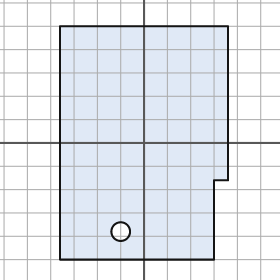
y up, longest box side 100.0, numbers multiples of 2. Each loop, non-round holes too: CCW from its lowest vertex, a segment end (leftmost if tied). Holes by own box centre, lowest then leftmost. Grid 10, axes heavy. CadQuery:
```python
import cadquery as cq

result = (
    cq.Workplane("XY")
    .moveTo(-36.0, -50.0)
    .lineTo(30.0, -50.0)
    .lineTo(30.0, -16.0)
    .lineTo(36.0, -16.0)
    .lineTo(36.0, 50.0)
    .lineTo(-36.0, 50.0)
    .close()
    .moveTo(-10.0, -38.0)
    .circle(4.0)
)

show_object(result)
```